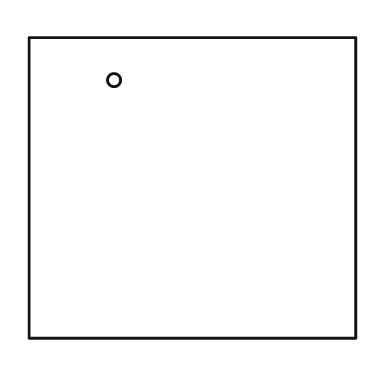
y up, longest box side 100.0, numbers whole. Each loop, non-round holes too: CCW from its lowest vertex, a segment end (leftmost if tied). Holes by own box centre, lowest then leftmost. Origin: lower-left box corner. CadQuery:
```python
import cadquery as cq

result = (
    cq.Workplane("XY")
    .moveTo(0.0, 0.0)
    .lineTo(100.0, 0.0)
    .lineTo(100.0, 92.0)
    .lineTo(0.0, 92.0)
    .close()
    .moveTo(26.0, 79.0)
    .circle(2.0)
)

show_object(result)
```